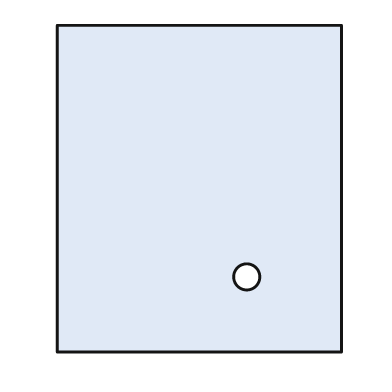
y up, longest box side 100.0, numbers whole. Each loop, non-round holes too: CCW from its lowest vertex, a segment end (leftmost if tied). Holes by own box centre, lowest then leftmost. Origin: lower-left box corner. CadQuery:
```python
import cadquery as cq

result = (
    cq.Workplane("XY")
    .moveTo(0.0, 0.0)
    .lineTo(87.0, 0.0)
    .lineTo(87.0, 100.0)
    .lineTo(0.0, 100.0)
    .close()
    .moveTo(58.0, 23.0)
    .circle(4.0)
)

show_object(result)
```